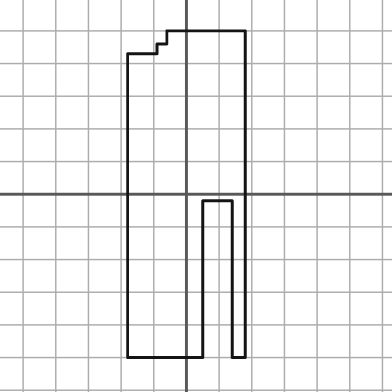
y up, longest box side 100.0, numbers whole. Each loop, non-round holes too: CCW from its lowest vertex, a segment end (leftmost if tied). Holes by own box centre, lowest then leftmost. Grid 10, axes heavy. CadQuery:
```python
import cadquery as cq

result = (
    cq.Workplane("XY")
    .moveTo(-18.0, -50.0)
    .lineTo(5.0, -50.0)
    .lineTo(5.0, -2.0)
    .lineTo(14.0, -2.0)
    .lineTo(14.0, -50.0)
    .lineTo(18.0, -50.0)
    .lineTo(18.0, 50.0)
    .lineTo(-6.0, 50.0)
    .lineTo(-6.0, 46.0)
    .lineTo(-9.0, 46.0)
    .lineTo(-9.0, 43.0)
    .lineTo(-18.0, 43.0)
    .close()
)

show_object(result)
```